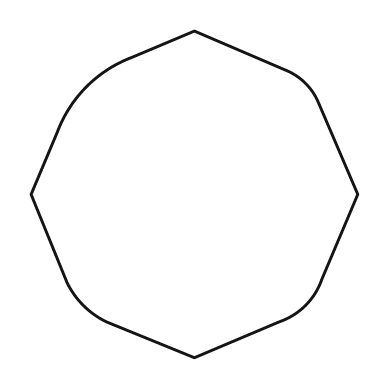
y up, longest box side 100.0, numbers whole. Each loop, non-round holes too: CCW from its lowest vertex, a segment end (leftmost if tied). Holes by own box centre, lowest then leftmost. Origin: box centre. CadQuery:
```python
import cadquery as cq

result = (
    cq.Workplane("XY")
    .moveTo(0.0, -50.0)
    .lineTo(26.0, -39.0)
    .threePointArc((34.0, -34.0), (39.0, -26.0))
    .lineTo(50.0, 0.0)
    .lineTo(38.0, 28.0)
    .threePointArc((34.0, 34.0), (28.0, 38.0))
    .lineTo(0.0, 50.0)
    .lineTo(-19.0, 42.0)
    .threePointArc((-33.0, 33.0), (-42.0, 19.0))
    .lineTo(-50.0, 0.0)
    .lineTo(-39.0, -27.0)
    .threePointArc((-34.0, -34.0), (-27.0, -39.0))
    .close()
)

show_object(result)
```